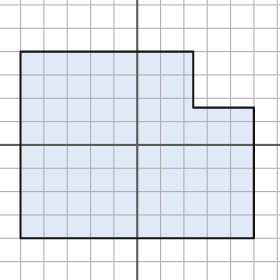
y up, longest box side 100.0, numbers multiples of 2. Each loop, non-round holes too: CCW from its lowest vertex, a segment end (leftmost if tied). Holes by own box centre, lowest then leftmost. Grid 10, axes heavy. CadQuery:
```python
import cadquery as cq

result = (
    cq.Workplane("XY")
    .moveTo(-50.0, -40.0)
    .lineTo(50.0, -40.0)
    .lineTo(50.0, 16.0)
    .lineTo(24.0, 16.0)
    .lineTo(24.0, 40.0)
    .lineTo(-50.0, 40.0)
    .close()
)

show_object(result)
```